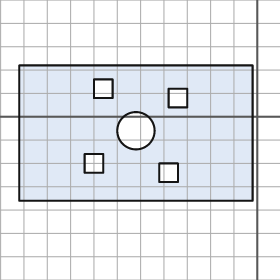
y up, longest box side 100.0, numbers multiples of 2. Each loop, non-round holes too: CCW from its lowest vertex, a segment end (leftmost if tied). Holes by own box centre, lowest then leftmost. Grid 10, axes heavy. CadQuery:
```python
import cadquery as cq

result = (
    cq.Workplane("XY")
    .moveTo(-102.0, -36.0)
    .lineTo(-2.0, -36.0)
    .lineTo(-2.0, 22.0)
    .lineTo(-102.0, 22.0)
    .close()
    .moveTo(-42.0, -28.0)
    .lineTo(-34.0, -28.0)
    .lineTo(-34.0, -20.0)
    .lineTo(-42.0, -20.0)
    .close()
    .moveTo(-74.0, -24.0)
    .lineTo(-66.0, -24.0)
    .lineTo(-66.0, -16.0)
    .lineTo(-74.0, -16.0)
    .close()
    .moveTo(-52.0, -6.0)
    .circle(8.0)
    .moveTo(-38.0, 4.0)
    .lineTo(-30.0, 4.0)
    .lineTo(-30.0, 12.0)
    .lineTo(-38.0, 12.0)
    .close()
    .moveTo(-70.0, 8.0)
    .lineTo(-62.0, 8.0)
    .lineTo(-62.0, 16.0)
    .lineTo(-70.0, 16.0)
    .close()
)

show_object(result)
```